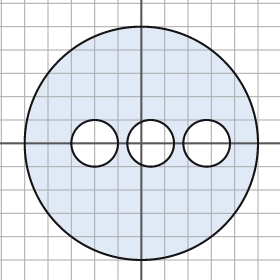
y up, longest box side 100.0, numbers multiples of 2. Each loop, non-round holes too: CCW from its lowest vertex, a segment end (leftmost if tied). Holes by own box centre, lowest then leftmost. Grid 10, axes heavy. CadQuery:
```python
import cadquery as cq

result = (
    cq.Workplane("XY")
    .moveTo(0.0, 0.0)
    .circle(50.0)
    .moveTo(-20.0, 0.0)
    .circle(10.0)
    .moveTo(4.0, 0.0)
    .circle(10.0)
    .moveTo(28.0, 0.0)
    .circle(10.0)
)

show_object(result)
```